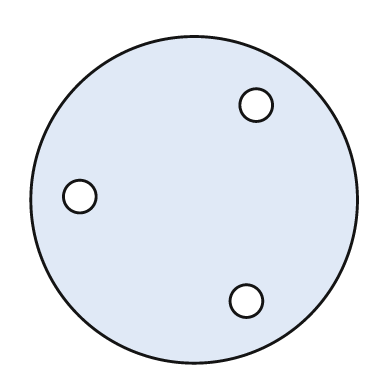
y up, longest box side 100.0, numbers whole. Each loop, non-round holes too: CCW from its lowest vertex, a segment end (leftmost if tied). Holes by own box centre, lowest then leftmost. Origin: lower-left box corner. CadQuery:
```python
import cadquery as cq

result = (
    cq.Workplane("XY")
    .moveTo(50.0, 50.0)
    .circle(50.0)
    .moveTo(66.0, 19.0)
    .circle(5.0)
    .moveTo(15.0, 51.0)
    .circle(5.0)
    .moveTo(69.0, 79.0)
    .circle(5.0)
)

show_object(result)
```